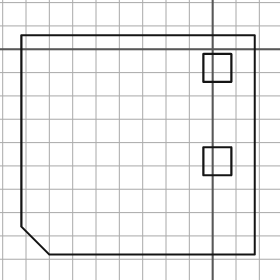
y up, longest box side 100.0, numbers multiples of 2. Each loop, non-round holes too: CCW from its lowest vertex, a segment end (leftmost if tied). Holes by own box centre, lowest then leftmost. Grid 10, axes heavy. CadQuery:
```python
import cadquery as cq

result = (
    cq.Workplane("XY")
    .moveTo(-70.0, -88.0)
    .lineTo(18.0, -88.0)
    .lineTo(18.0, 6.0)
    .lineTo(-82.0, 6.0)
    .lineTo(-82.0, -76.0)
    .close()
    .moveTo(-4.0, -54.0)
    .lineTo(8.0, -54.0)
    .lineTo(8.0, -42.0)
    .lineTo(-4.0, -42.0)
    .close()
    .moveTo(-4.0, -14.0)
    .lineTo(8.0, -14.0)
    .lineTo(8.0, -2.0)
    .lineTo(-4.0, -2.0)
    .close()
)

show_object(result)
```